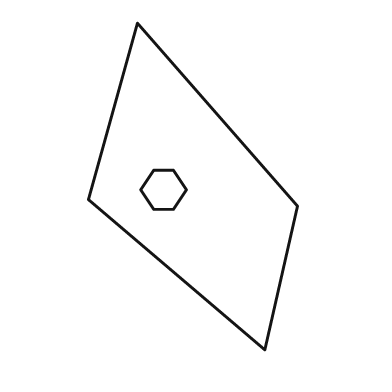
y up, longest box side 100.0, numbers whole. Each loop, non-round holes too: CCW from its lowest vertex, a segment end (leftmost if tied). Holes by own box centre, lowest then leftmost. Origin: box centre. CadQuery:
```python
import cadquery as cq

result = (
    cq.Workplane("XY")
    .moveTo(22.0, -50.0)
    .lineTo(32.0, -6.0)
    .lineTo(-17.0, 50.0)
    .lineTo(-32.0, -4.0)
    .close()
    .moveTo(-12.0, -7.0)
    .lineTo(-6.0, -7.0)
    .lineTo(-2.0, -1.0)
    .lineTo(-6.0, 5.0)
    .lineTo(-12.0, 5.0)
    .lineTo(-16.0, -1.0)
    .close()
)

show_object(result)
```